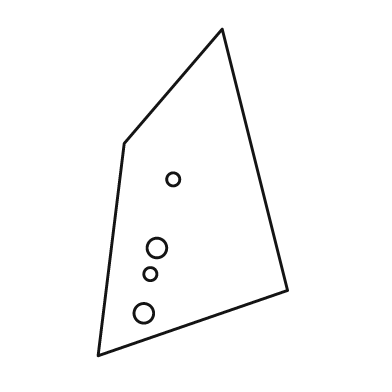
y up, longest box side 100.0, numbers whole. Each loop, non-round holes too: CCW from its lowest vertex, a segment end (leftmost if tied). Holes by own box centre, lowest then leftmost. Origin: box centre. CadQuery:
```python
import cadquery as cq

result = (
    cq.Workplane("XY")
    .moveTo(-29.0, -50.0)
    .lineTo(29.0, -30.0)
    .lineTo(9.0, 50.0)
    .lineTo(-21.0, 15.0)
    .close()
    .moveTo(-15.0, -37.0)
    .circle(3.0)
    .moveTo(-13.0, -25.0)
    .circle(2.0)
    .moveTo(-11.0, -17.0)
    .circle(3.0)
    .moveTo(-6.0, 4.0)
    .circle(2.0)
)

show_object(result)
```